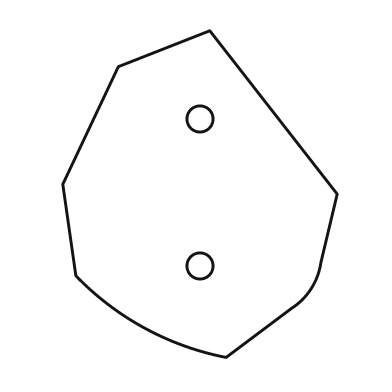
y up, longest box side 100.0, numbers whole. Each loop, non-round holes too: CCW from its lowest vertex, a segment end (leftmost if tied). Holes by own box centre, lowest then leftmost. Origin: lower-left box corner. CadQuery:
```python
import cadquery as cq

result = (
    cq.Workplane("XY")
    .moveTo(50.0, 0.0)
    .lineTo(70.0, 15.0)
    .threePointArc((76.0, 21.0), (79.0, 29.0))
    .lineTo(84.0, 50.0)
    .lineTo(45.0, 100.0)
    .lineTo(17.0, 89.0)
    .lineTo(0.0, 53.0)
    .lineTo(4.0, 25.0)
    .threePointArc((25.0, 9.0), (50.0, 0.0))
    .close()
    .moveTo(42.0, 28.0)
    .circle(4.0)
    .moveTo(42.0, 73.0)
    .circle(4.0)
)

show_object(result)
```